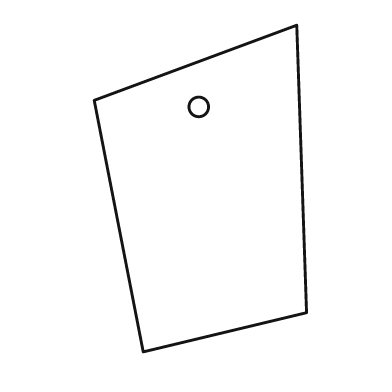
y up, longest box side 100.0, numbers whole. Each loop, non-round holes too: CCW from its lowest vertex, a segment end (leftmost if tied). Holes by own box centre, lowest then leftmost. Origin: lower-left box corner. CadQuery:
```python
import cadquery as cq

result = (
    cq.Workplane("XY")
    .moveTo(15.0, 0.0)
    .lineTo(65.0, 12.0)
    .lineTo(62.0, 100.0)
    .lineTo(0.0, 77.0)
    .close()
    .moveTo(32.0, 75.0)
    .circle(3.0)
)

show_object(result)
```